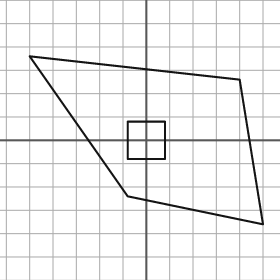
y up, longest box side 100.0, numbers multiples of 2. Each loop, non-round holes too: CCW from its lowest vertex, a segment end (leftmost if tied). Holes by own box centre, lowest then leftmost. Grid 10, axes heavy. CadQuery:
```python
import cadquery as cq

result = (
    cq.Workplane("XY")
    .moveTo(50.0, -36.0)
    .lineTo(40.0, 26.0)
    .lineTo(-50.0, 36.0)
    .lineTo(-8.0, -24.0)
    .close()
    .moveTo(-8.0, -8.0)
    .lineTo(8.0, -8.0)
    .lineTo(8.0, 8.0)
    .lineTo(-8.0, 8.0)
    .close()
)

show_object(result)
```